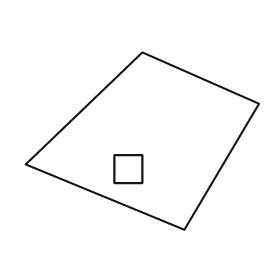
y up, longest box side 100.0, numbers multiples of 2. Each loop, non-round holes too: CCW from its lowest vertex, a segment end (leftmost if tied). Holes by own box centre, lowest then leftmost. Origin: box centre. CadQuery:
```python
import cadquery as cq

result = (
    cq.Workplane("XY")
    .moveTo(18.0, -38.0)
    .lineTo(50.0, 16.0)
    .lineTo(0.0, 38.0)
    .lineTo(-50.0, -10.0)
    .close()
    .moveTo(-12.0, -18.0)
    .lineTo(0.0, -18.0)
    .lineTo(0.0, -6.0)
    .lineTo(-12.0, -6.0)
    .close()
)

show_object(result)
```